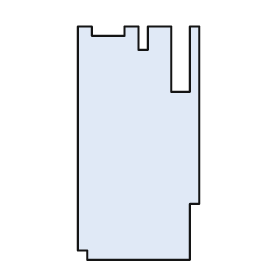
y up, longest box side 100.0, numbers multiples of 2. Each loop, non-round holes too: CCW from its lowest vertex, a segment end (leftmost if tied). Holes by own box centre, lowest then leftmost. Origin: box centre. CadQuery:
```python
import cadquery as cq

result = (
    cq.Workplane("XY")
    .moveTo(-22.0, -50.0)
    .lineTo(22.0, -50.0)
    .lineTo(22.0, -26.0)
    .lineTo(26.0, -26.0)
    .lineTo(26.0, 50.0)
    .lineTo(22.0, 50.0)
    .lineTo(22.0, 22.0)
    .lineTo(14.0, 22.0)
    .lineTo(14.0, 50.0)
    .lineTo(4.0, 50.0)
    .lineTo(4.0, 40.0)
    .lineTo(0.0, 40.0)
    .lineTo(0.0, 50.0)
    .lineTo(-6.0, 50.0)
    .lineTo(-6.0, 46.0)
    .lineTo(-20.0, 46.0)
    .lineTo(-20.0, 50.0)
    .lineTo(-26.0, 50.0)
    .lineTo(-26.0, -46.0)
    .lineTo(-22.0, -46.0)
    .close()
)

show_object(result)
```